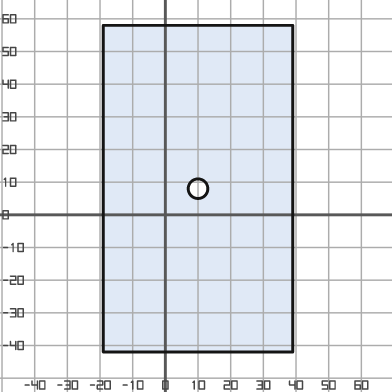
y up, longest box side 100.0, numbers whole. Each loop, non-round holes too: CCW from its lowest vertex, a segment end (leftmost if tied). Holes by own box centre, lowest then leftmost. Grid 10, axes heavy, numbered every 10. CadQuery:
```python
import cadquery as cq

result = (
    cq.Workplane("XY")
    .moveTo(-19.0, -42.0)
    .lineTo(39.0, -42.0)
    .lineTo(39.0, 58.0)
    .lineTo(-19.0, 58.0)
    .close()
    .moveTo(10.0, 8.0)
    .circle(3.0)
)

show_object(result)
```